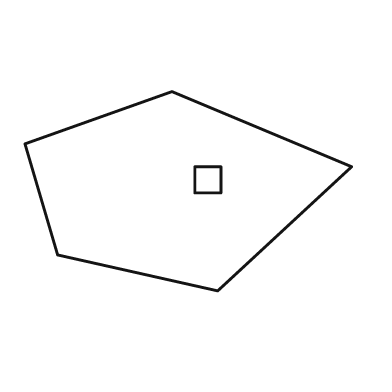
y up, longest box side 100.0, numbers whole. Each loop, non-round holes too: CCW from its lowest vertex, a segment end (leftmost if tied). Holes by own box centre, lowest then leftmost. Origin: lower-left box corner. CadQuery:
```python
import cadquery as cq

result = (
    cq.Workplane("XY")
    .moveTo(59.0, 0.0)
    .lineTo(100.0, 38.0)
    .lineTo(45.0, 61.0)
    .lineTo(0.0, 45.0)
    .lineTo(10.0, 11.0)
    .close()
    .moveTo(52.0, 30.0)
    .lineTo(60.0, 30.0)
    .lineTo(60.0, 38.0)
    .lineTo(52.0, 38.0)
    .close()
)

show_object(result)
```